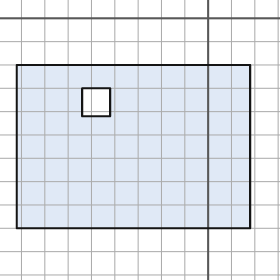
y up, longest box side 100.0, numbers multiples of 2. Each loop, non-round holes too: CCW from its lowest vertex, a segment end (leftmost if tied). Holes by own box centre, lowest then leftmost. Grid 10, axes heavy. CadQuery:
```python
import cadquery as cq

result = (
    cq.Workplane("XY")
    .moveTo(-82.0, -90.0)
    .lineTo(18.0, -90.0)
    .lineTo(18.0, -20.0)
    .lineTo(-82.0, -20.0)
    .close()
    .moveTo(-54.0, -42.0)
    .lineTo(-42.0, -42.0)
    .lineTo(-42.0, -30.0)
    .lineTo(-54.0, -30.0)
    .close()
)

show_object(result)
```